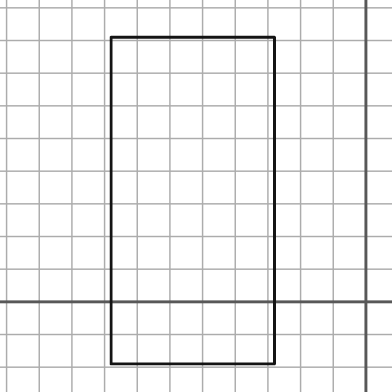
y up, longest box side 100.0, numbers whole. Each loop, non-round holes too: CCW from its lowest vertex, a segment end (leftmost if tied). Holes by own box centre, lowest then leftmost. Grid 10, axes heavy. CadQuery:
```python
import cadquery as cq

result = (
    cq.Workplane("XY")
    .moveTo(-78.0, -19.0)
    .lineTo(-28.0, -19.0)
    .lineTo(-28.0, 81.0)
    .lineTo(-78.0, 81.0)
    .close()
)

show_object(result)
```